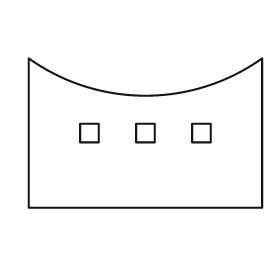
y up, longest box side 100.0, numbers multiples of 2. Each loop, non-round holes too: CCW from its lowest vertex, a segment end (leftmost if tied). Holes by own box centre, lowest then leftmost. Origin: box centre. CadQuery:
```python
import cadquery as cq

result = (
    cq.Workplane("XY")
    .moveTo(-50.0, -32.0)
    .lineTo(50.0, -32.0)
    .lineTo(50.0, 32.0)
    .threePointArc((0.0, 16.0), (-50.0, 32.0))
    .close()
    .moveTo(-28.0, -4.0)
    .lineTo(-20.0, -4.0)
    .lineTo(-20.0, 4.0)
    .lineTo(-28.0, 4.0)
    .close()
    .moveTo(-4.0, -4.0)
    .lineTo(4.0, -4.0)
    .lineTo(4.0, 4.0)
    .lineTo(-4.0, 4.0)
    .close()
    .moveTo(20.0, -4.0)
    .lineTo(28.0, -4.0)
    .lineTo(28.0, 4.0)
    .lineTo(20.0, 4.0)
    .close()
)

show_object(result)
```